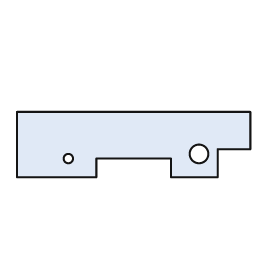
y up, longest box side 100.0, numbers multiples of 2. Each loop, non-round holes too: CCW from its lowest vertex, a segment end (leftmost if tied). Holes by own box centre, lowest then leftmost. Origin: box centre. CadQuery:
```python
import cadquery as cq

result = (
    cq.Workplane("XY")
    .moveTo(-50.0, -14.0)
    .lineTo(-16.0, -14.0)
    .lineTo(-16.0, -6.0)
    .lineTo(16.0, -6.0)
    .lineTo(16.0, -14.0)
    .lineTo(36.0, -14.0)
    .lineTo(36.0, -2.0)
    .lineTo(50.0, -2.0)
    .lineTo(50.0, 14.0)
    .lineTo(-50.0, 14.0)
    .close()
    .moveTo(-28.0, -6.0)
    .circle(2.0)
    .moveTo(28.0, -4.0)
    .circle(4.0)
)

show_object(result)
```